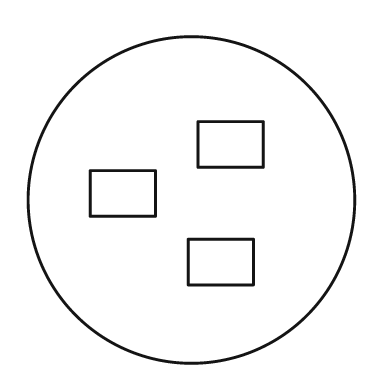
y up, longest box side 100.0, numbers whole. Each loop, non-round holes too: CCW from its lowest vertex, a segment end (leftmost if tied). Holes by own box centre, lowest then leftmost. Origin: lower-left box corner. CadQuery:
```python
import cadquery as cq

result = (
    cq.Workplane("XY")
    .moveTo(50.0, 50.0)
    .circle(50.0)
    .moveTo(49.0, 24.0)
    .lineTo(69.0, 24.0)
    .lineTo(69.0, 38.0)
    .lineTo(49.0, 38.0)
    .close()
    .moveTo(19.0, 45.0)
    .lineTo(39.0, 45.0)
    .lineTo(39.0, 59.0)
    .lineTo(19.0, 59.0)
    .close()
    .moveTo(52.0, 60.0)
    .lineTo(72.0, 60.0)
    .lineTo(72.0, 74.0)
    .lineTo(52.0, 74.0)
    .close()
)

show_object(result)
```